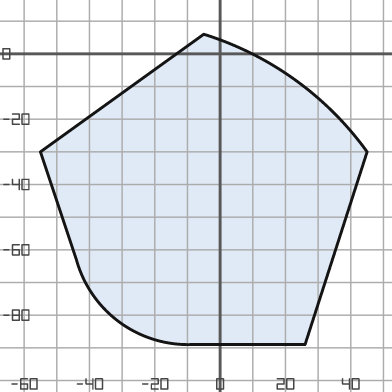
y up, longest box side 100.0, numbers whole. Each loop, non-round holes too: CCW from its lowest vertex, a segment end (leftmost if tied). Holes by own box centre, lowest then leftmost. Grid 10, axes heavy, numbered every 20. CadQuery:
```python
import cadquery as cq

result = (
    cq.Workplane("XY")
    .moveTo(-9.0, -89.0)
    .lineTo(26.0, -89.0)
    .lineTo(45.0, -30.0)
    .threePointArc((23.0, -8.0), (-5.0, 6.0))
    .lineTo(-55.0, -30.0)
    .lineTo(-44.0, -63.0)
    .threePointArc((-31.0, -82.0), (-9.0, -89.0))
    .close()
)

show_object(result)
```